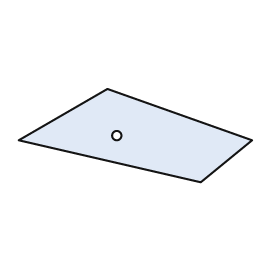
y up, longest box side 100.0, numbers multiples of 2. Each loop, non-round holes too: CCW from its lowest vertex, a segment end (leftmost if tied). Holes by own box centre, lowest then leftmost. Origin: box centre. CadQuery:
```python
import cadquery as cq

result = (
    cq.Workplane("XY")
    .moveTo(28.0, -20.0)
    .lineTo(50.0, -2.0)
    .lineTo(-12.0, 20.0)
    .lineTo(-50.0, -2.0)
    .close()
    .moveTo(-8.0, 0.0)
    .circle(2.0)
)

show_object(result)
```